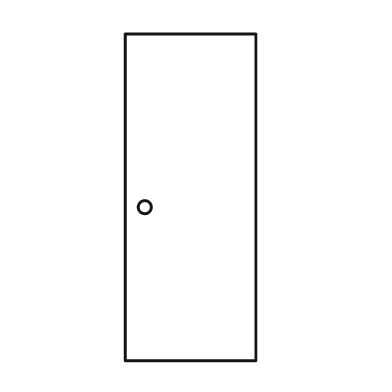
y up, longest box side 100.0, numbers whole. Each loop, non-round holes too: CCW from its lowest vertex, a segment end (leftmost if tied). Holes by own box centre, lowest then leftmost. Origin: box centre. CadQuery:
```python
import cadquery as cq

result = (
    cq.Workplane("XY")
    .moveTo(-20.0, -50.0)
    .lineTo(20.0, -50.0)
    .lineTo(20.0, 50.0)
    .lineTo(-20.0, 50.0)
    .close()
    .moveTo(-14.0, -3.0)
    .circle(2.0)
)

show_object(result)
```